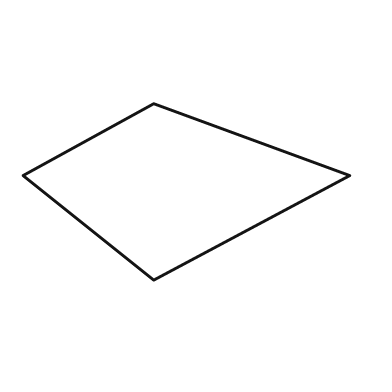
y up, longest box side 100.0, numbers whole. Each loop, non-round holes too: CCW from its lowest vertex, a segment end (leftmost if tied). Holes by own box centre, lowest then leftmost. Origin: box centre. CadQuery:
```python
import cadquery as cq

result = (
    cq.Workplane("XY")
    .moveTo(-10.0, -27.0)
    .lineTo(50.0, 5.0)
    .lineTo(-10.0, 27.0)
    .lineTo(-50.0, 5.0)
    .close()
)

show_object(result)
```